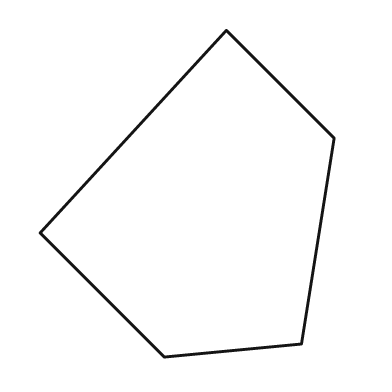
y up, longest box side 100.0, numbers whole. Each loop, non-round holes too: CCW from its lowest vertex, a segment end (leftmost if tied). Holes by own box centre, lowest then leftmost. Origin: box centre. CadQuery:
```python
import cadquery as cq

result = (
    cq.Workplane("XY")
    .moveTo(-7.0, -50.0)
    .lineTo(35.0, -46.0)
    .lineTo(45.0, 17.0)
    .lineTo(12.0, 50.0)
    .lineTo(-45.0, -12.0)
    .close()
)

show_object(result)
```